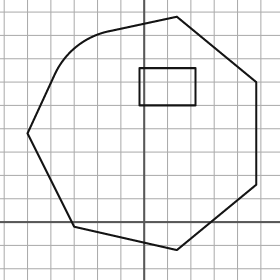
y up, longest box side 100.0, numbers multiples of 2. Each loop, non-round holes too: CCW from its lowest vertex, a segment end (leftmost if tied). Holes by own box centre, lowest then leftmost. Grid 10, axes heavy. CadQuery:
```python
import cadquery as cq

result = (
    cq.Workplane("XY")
    .moveTo(14.0, -12.0)
    .lineTo(48.0, 16.0)
    .lineTo(48.0, 60.0)
    .lineTo(14.0, 88.0)
    .lineTo(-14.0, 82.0)
    .threePointArc((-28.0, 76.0), (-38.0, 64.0))
    .lineTo(-50.0, 38.0)
    .lineTo(-30.0, -2.0)
    .close()
    .moveTo(-2.0, 50.0)
    .lineTo(22.0, 50.0)
    .lineTo(22.0, 66.0)
    .lineTo(-2.0, 66.0)
    .close()
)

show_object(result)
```